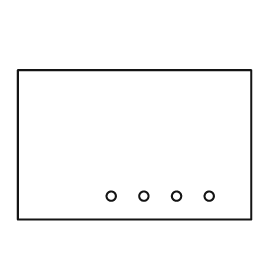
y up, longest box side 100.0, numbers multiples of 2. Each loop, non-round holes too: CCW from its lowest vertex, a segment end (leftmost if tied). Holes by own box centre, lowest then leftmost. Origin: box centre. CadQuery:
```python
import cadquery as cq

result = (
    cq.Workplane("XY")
    .moveTo(-50.0, -32.0)
    .lineTo(50.0, -32.0)
    .lineTo(50.0, 32.0)
    .lineTo(-50.0, 32.0)
    .close()
    .moveTo(-10.0, -22.0)
    .circle(2.0)
    .moveTo(4.0, -22.0)
    .circle(2.0)
    .moveTo(18.0, -22.0)
    .circle(2.0)
    .moveTo(32.0, -22.0)
    .circle(2.0)
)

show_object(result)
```